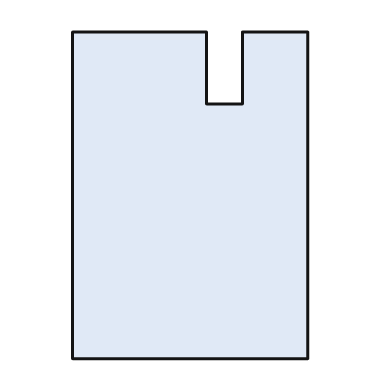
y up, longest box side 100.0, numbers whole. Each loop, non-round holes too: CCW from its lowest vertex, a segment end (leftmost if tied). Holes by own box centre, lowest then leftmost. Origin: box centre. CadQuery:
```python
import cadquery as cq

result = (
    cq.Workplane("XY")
    .moveTo(-36.0, -50.0)
    .lineTo(36.0, -50.0)
    .lineTo(36.0, 50.0)
    .lineTo(16.0, 50.0)
    .lineTo(16.0, 28.0)
    .lineTo(5.0, 28.0)
    .lineTo(5.0, 50.0)
    .lineTo(-36.0, 50.0)
    .close()
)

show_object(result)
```